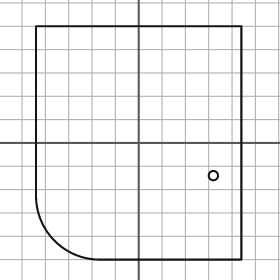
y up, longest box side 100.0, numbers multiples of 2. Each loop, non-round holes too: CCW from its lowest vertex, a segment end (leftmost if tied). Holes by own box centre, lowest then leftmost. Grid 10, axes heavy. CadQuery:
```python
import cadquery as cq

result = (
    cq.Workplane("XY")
    .moveTo(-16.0, -50.0)
    .lineTo(44.0, -50.0)
    .lineTo(44.0, 50.0)
    .lineTo(-44.0, 50.0)
    .lineTo(-44.0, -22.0)
    .threePointArc((-36.0, -42.0), (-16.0, -50.0))
    .close()
    .moveTo(32.0, -14.0)
    .circle(2.0)
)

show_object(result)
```